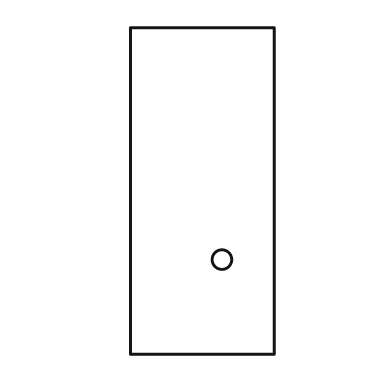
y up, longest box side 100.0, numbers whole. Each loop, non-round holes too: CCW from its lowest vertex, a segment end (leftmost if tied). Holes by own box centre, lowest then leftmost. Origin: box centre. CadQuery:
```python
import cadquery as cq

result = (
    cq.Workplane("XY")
    .moveTo(-22.0, -50.0)
    .lineTo(22.0, -50.0)
    .lineTo(22.0, 50.0)
    .lineTo(-22.0, 50.0)
    .close()
    .moveTo(6.0, -21.0)
    .circle(3.0)
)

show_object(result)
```